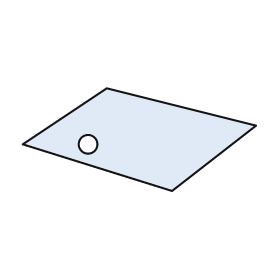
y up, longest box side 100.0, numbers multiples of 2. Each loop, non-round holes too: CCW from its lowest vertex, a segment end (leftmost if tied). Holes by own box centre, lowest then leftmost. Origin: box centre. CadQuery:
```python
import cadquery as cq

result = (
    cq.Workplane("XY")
    .moveTo(14.0, -22.0)
    .lineTo(50.0, 6.0)
    .lineTo(-14.0, 22.0)
    .lineTo(-50.0, -2.0)
    .close()
    .moveTo(-22.0, -2.0)
    .circle(4.0)
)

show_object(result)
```